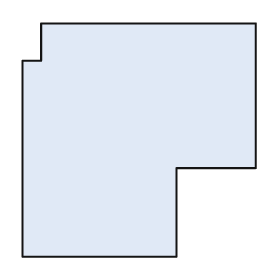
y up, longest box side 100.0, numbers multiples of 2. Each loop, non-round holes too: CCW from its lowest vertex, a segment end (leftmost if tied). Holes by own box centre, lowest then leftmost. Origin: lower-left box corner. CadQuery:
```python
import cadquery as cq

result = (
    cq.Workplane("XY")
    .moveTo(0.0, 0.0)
    .lineTo(66.0, 0.0)
    .lineTo(66.0, 38.0)
    .lineTo(100.0, 38.0)
    .lineTo(100.0, 100.0)
    .lineTo(8.0, 100.0)
    .lineTo(8.0, 84.0)
    .lineTo(0.0, 84.0)
    .close()
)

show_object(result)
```